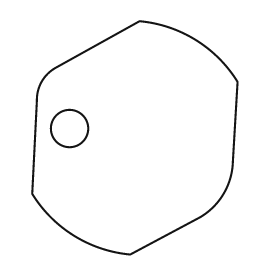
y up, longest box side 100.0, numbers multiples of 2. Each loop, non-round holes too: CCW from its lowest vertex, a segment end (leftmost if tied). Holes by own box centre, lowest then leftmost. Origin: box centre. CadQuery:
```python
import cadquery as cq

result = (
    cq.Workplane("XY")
    .moveTo(-2.0, -50.0)
    .lineTo(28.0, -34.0)
    .threePointArc((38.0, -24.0), (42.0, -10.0))
    .lineTo(44.0, 24.0)
    .threePointArc((26.0, 42.0), (2.0, 50.0))
    .lineTo(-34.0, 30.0)
    .threePointArc((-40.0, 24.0), (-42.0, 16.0))
    .lineTo(-44.0, -24.0)
    .threePointArc((-26.0, -42.0), (-2.0, -50.0))
    .close()
    .moveTo(-28.0, 4.0)
    .circle(8.0)
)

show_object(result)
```